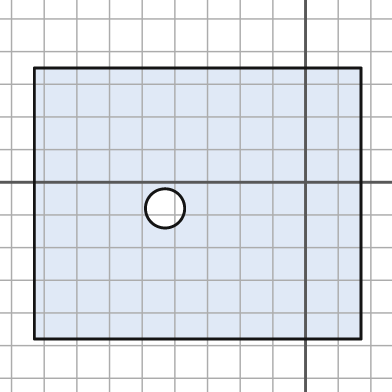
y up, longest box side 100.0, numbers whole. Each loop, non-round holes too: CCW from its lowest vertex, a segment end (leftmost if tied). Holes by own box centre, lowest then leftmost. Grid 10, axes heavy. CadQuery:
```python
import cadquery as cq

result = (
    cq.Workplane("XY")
    .moveTo(-83.0, -48.0)
    .lineTo(17.0, -48.0)
    .lineTo(17.0, 35.0)
    .lineTo(-83.0, 35.0)
    .close()
    .moveTo(-43.0, -8.0)
    .circle(6.0)
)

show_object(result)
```